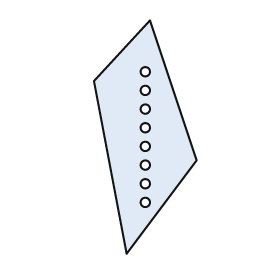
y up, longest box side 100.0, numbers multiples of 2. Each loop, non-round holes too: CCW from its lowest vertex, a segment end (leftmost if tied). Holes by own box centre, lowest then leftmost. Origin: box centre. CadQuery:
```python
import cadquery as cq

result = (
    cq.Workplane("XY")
    .moveTo(-8.0, -50.0)
    .lineTo(22.0, -10.0)
    .lineTo(2.0, 50.0)
    .lineTo(-22.0, 24.0)
    .close()
    .moveTo(0.0, -28.0)
    .circle(2.0)
    .moveTo(0.0, -20.0)
    .circle(2.0)
    .moveTo(0.0, -12.0)
    .circle(2.0)
    .moveTo(0.0, -4.0)
    .circle(2.0)
    .moveTo(0.0, 4.0)
    .circle(2.0)
    .moveTo(0.0, 12.0)
    .circle(2.0)
    .moveTo(0.0, 20.0)
    .circle(2.0)
    .moveTo(0.0, 28.0)
    .circle(2.0)
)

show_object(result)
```